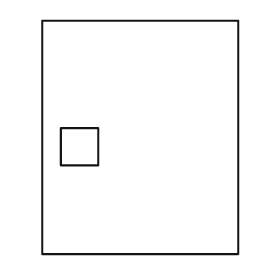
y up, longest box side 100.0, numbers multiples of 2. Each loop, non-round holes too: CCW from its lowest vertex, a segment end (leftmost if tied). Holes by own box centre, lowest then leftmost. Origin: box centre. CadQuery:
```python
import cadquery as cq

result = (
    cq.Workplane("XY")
    .moveTo(-42.0, -50.0)
    .lineTo(42.0, -50.0)
    .lineTo(42.0, 50.0)
    .lineTo(-42.0, 50.0)
    .close()
    .moveTo(-34.0, -12.0)
    .lineTo(-18.0, -12.0)
    .lineTo(-18.0, 4.0)
    .lineTo(-34.0, 4.0)
    .close()
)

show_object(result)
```